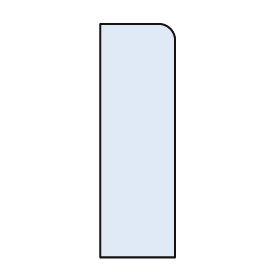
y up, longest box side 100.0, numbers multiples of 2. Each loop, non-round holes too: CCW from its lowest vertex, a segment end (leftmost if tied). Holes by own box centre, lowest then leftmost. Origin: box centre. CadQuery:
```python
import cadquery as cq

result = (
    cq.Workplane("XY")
    .moveTo(-16.0, -50.0)
    .lineTo(16.0, -50.0)
    .lineTo(16.0, 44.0)
    .threePointArc((14.0, 48.0), (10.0, 50.0))
    .lineTo(-16.0, 50.0)
    .close()
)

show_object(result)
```